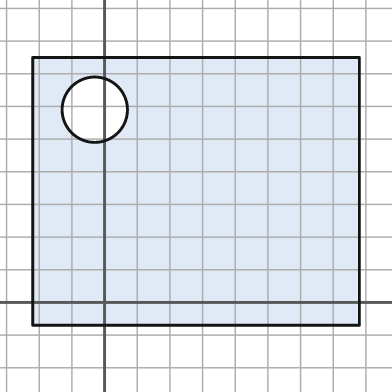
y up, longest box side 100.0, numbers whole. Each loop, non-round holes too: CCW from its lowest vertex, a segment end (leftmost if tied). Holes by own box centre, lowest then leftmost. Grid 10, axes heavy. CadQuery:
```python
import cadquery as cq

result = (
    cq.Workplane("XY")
    .moveTo(-22.0, -7.0)
    .lineTo(78.0, -7.0)
    .lineTo(78.0, 75.0)
    .lineTo(-22.0, 75.0)
    .close()
    .moveTo(-3.0, 59.0)
    .circle(10.0)
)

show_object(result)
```